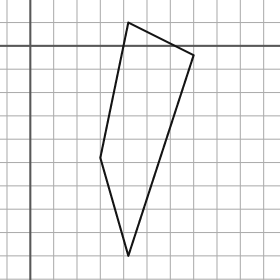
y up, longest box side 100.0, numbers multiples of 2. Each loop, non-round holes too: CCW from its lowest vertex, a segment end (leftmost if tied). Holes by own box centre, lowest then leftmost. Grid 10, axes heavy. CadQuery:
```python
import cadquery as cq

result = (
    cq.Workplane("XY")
    .moveTo(42.0, -90.0)
    .lineTo(70.0, -4.0)
    .lineTo(42.0, 10.0)
    .lineTo(30.0, -48.0)
    .close()
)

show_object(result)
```